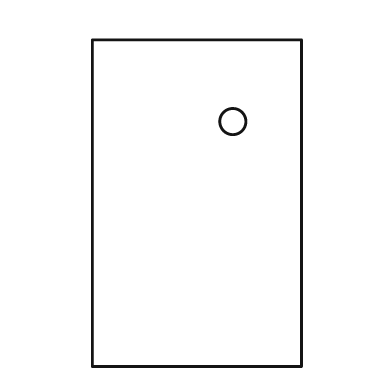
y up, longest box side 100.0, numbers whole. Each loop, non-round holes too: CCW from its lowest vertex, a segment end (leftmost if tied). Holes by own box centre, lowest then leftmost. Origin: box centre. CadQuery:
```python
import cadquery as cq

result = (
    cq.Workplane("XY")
    .moveTo(-32.0, -50.0)
    .lineTo(32.0, -50.0)
    .lineTo(32.0, 50.0)
    .lineTo(-32.0, 50.0)
    .close()
    .moveTo(11.0, 25.0)
    .circle(4.0)
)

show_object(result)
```